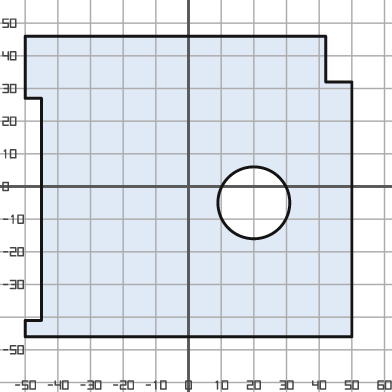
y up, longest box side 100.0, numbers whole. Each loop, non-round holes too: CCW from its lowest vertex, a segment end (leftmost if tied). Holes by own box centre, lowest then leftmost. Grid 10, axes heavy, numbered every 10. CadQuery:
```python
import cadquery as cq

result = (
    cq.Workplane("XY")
    .moveTo(-50.0, -46.0)
    .lineTo(50.0, -46.0)
    .lineTo(50.0, 32.0)
    .lineTo(42.0, 32.0)
    .lineTo(42.0, 46.0)
    .lineTo(-50.0, 46.0)
    .lineTo(-50.0, 27.0)
    .lineTo(-45.0, 27.0)
    .lineTo(-45.0, -41.0)
    .lineTo(-50.0, -41.0)
    .close()
    .moveTo(20.0, -5.0)
    .circle(11.0)
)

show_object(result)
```